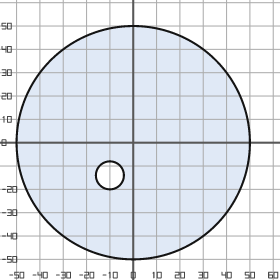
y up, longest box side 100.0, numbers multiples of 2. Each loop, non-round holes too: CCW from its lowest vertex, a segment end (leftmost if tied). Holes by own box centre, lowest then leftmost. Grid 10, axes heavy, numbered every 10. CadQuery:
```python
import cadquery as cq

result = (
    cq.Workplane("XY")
    .moveTo(0.0, 0.0)
    .circle(50.0)
    .moveTo(-10.0, -14.0)
    .circle(6.0)
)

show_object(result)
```